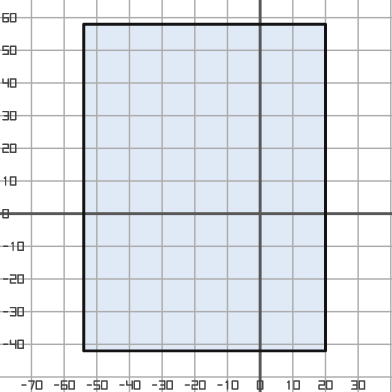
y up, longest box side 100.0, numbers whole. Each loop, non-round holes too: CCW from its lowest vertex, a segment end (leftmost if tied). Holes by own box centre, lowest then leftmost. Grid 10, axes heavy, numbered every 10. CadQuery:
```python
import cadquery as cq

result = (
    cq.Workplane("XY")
    .moveTo(-54.0, -42.0)
    .lineTo(20.0, -42.0)
    .lineTo(20.0, 58.0)
    .lineTo(-54.0, 58.0)
    .close()
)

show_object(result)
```